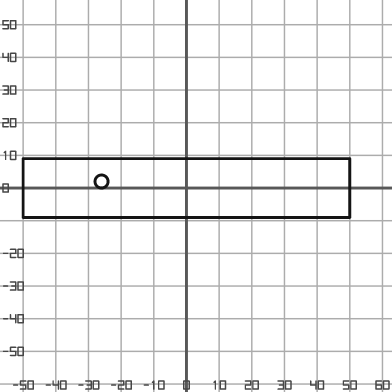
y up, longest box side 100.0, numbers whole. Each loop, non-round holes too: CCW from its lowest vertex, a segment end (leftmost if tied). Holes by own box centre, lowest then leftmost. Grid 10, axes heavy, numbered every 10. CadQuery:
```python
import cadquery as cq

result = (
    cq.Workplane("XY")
    .moveTo(-50.0, -9.0)
    .lineTo(50.0, -9.0)
    .lineTo(50.0, 9.0)
    .lineTo(-50.0, 9.0)
    .close()
    .moveTo(-26.0, 2.0)
    .circle(2.0)
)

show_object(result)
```